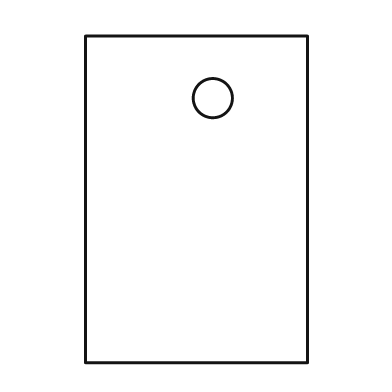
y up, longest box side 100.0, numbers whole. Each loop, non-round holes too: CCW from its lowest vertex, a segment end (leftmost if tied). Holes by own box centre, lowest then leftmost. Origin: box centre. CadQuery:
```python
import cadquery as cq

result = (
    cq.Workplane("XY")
    .moveTo(-34.0, -50.0)
    .lineTo(34.0, -50.0)
    .lineTo(34.0, 50.0)
    .lineTo(-34.0, 50.0)
    .close()
    .moveTo(5.0, 31.0)
    .circle(6.0)
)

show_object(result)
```